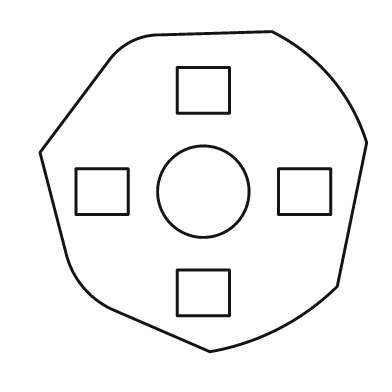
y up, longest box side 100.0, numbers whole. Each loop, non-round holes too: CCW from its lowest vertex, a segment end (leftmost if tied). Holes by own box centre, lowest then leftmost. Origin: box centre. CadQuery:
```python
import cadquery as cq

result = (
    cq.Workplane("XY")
    .moveTo(2.0, -49.0)
    .threePointArc((23.0, -42.0), (41.0, -29.0))
    .lineTo(50.0, 15.0)
    .threePointArc((39.0, 35.0), (21.0, 49.0))
    .lineTo(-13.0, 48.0)
    .threePointArc((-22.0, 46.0), (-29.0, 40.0))
    .lineTo(-50.0, 12.0)
    .lineTo(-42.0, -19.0)
    .threePointArc((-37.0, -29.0), (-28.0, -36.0))
    .close()
    .moveTo(-8.0, -38.0)
    .lineTo(8.0, -38.0)
    .lineTo(8.0, -24.0)
    .lineTo(-8.0, -24.0)
    .close()
    .moveTo(-39.0, -7.0)
    .lineTo(-23.0, -7.0)
    .lineTo(-23.0, 7.0)
    .lineTo(-39.0, 7.0)
    .close()
    .moveTo(0.0, 0.0)
    .circle(14.0)
    .moveTo(23.0, -7.0)
    .lineTo(39.0, -7.0)
    .lineTo(39.0, 7.0)
    .lineTo(23.0, 7.0)
    .close()
    .moveTo(-8.0, 24.0)
    .lineTo(8.0, 24.0)
    .lineTo(8.0, 38.0)
    .lineTo(-8.0, 38.0)
    .close()
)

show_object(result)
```